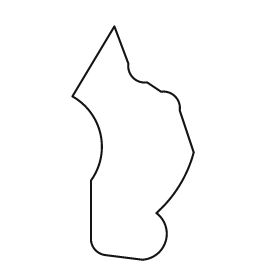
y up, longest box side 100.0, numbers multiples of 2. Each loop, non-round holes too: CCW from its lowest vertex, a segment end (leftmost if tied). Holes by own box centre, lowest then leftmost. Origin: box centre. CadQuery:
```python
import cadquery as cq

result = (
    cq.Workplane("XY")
    .moveTo(4.0, -50.0)
    .threePointArc((14.0, -42.0), (10.0, -30.0))
    .threePointArc((20.0, -18.0), (26.0, -4.0))
    .lineTo(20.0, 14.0)
    .threePointArc((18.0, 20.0), (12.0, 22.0))
    .lineTo(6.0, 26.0)
    .threePointArc((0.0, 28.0), (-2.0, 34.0))
    .lineTo(-8.0, 50.0)
    .lineTo(-26.0, 20.0)
    .threePointArc((-14.0, 4.0), (-18.0, -16.0))
    .lineTo(-18.0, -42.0)
    .threePointArc((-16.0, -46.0), (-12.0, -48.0))
    .close()
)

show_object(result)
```